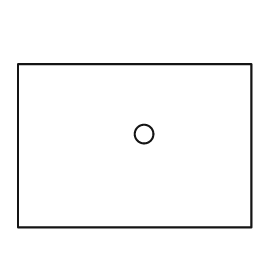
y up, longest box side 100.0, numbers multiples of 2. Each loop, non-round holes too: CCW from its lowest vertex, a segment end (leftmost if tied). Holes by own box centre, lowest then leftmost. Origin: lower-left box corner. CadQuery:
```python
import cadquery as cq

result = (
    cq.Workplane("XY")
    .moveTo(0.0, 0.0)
    .lineTo(100.0, 0.0)
    .lineTo(100.0, 70.0)
    .lineTo(0.0, 70.0)
    .close()
    .moveTo(54.0, 40.0)
    .circle(4.0)
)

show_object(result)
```